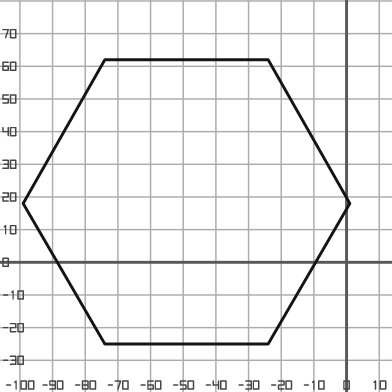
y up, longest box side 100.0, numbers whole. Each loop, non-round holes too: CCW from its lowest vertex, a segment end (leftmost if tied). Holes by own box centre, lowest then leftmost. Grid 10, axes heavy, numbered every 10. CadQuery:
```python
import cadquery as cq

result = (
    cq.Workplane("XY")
    .moveTo(-74.0, -25.0)
    .lineTo(-24.0, -25.0)
    .lineTo(1.0, 18.0)
    .lineTo(-24.0, 62.0)
    .lineTo(-74.0, 62.0)
    .lineTo(-99.0, 18.0)
    .close()
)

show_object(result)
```